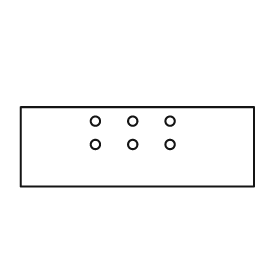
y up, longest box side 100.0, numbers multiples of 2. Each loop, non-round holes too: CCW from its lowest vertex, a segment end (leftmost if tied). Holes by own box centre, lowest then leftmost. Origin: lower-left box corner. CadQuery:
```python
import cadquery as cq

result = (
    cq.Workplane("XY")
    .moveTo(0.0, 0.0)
    .lineTo(100.0, 0.0)
    .lineTo(100.0, 34.0)
    .lineTo(0.0, 34.0)
    .close()
    .moveTo(32.0, 18.0)
    .circle(2.0)
    .moveTo(48.0, 18.0)
    .circle(2.0)
    .moveTo(64.0, 18.0)
    .circle(2.0)
    .moveTo(32.0, 28.0)
    .circle(2.0)
    .moveTo(48.0, 28.0)
    .circle(2.0)
    .moveTo(64.0, 28.0)
    .circle(2.0)
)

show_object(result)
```